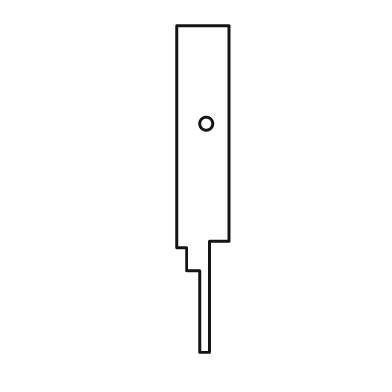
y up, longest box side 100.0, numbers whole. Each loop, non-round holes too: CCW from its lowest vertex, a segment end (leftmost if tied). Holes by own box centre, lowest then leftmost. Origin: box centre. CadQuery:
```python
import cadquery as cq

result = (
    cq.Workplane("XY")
    .moveTo(-1.0, -50.0)
    .lineTo(2.0, -50.0)
    .lineTo(2.0, -16.0)
    .lineTo(8.0, -16.0)
    .lineTo(8.0, 50.0)
    .lineTo(-8.0, 50.0)
    .lineTo(-8.0, -18.0)
    .lineTo(-5.0, -18.0)
    .lineTo(-5.0, -25.0)
    .lineTo(-1.0, -25.0)
    .close()
    .moveTo(1.0, 20.0)
    .circle(2.0)
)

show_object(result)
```